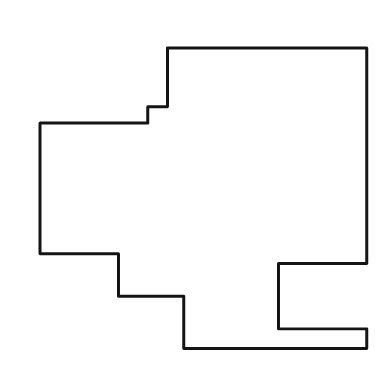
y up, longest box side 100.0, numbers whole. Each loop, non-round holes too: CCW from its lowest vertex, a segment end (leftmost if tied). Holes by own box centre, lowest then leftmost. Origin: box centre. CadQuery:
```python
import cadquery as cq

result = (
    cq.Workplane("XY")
    .moveTo(-6.0, -46.0)
    .lineTo(50.0, -46.0)
    .lineTo(50.0, -40.0)
    .lineTo(23.0, -40.0)
    .lineTo(23.0, -20.0)
    .lineTo(50.0, -20.0)
    .lineTo(50.0, 46.0)
    .lineTo(-11.0, 46.0)
    .lineTo(-11.0, 28.0)
    .lineTo(-17.0, 28.0)
    .lineTo(-17.0, 23.0)
    .lineTo(-50.0, 23.0)
    .lineTo(-50.0, -17.0)
    .lineTo(-26.0, -17.0)
    .lineTo(-26.0, -30.0)
    .lineTo(-6.0, -30.0)
    .close()
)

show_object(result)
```